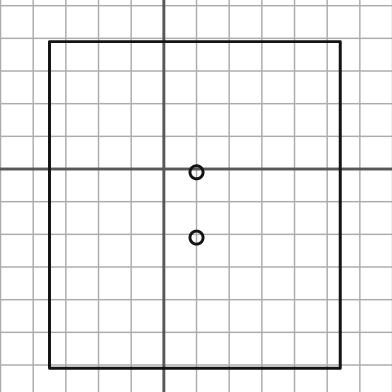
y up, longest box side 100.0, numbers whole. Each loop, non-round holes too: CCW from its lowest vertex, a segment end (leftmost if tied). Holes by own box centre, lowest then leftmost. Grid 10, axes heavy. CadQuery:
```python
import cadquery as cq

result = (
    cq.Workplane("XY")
    .moveTo(-35.0, -61.0)
    .lineTo(54.0, -61.0)
    .lineTo(54.0, 39.0)
    .lineTo(-35.0, 39.0)
    .close()
    .moveTo(10.0, -21.0)
    .circle(2.0)
    .moveTo(10.0, -1.0)
    .circle(2.0)
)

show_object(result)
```